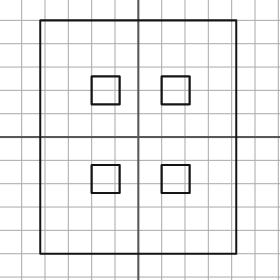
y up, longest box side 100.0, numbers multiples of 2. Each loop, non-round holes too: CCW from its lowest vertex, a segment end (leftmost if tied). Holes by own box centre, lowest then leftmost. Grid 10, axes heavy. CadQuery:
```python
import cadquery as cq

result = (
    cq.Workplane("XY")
    .moveTo(-42.0, -50.0)
    .lineTo(42.0, -50.0)
    .lineTo(42.0, 50.0)
    .lineTo(-42.0, 50.0)
    .close()
    .moveTo(-20.0, -24.0)
    .lineTo(-8.0, -24.0)
    .lineTo(-8.0, -12.0)
    .lineTo(-20.0, -12.0)
    .close()
    .moveTo(10.0, -24.0)
    .lineTo(22.0, -24.0)
    .lineTo(22.0, -12.0)
    .lineTo(10.0, -12.0)
    .close()
    .moveTo(-20.0, 14.0)
    .lineTo(-8.0, 14.0)
    .lineTo(-8.0, 26.0)
    .lineTo(-20.0, 26.0)
    .close()
    .moveTo(10.0, 14.0)
    .lineTo(22.0, 14.0)
    .lineTo(22.0, 26.0)
    .lineTo(10.0, 26.0)
    .close()
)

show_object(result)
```